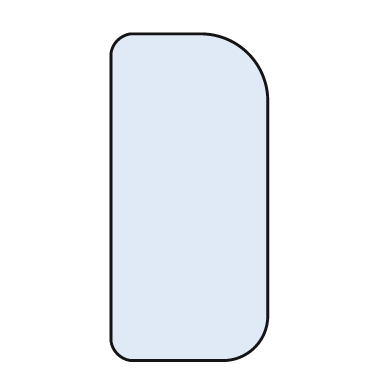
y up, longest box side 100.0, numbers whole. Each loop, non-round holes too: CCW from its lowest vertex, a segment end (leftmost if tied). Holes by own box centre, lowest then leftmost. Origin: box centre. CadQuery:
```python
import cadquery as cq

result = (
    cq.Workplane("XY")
    .moveTo(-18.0, -50.0)
    .lineTo(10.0, -50.0)
    .threePointArc((20.0, -46.0), (24.0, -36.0))
    .lineTo(24.0, 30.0)
    .threePointArc((18.0, 44.0), (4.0, 50.0))
    .lineTo(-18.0, 50.0)
    .threePointArc((-22.0, 48.0), (-24.0, 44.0))
    .lineTo(-24.0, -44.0)
    .threePointArc((-22.0, -48.0), (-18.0, -50.0))
    .close()
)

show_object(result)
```